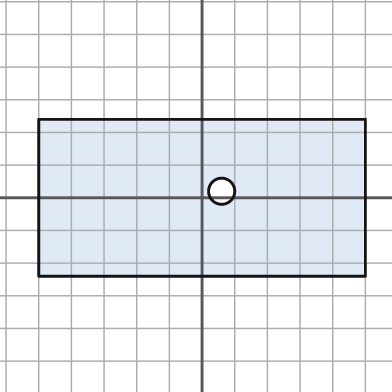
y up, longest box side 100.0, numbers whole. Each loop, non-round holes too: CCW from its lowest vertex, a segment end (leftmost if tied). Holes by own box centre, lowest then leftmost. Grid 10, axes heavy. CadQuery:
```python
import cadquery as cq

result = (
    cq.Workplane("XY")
    .moveTo(-50.0, -24.0)
    .lineTo(50.0, -24.0)
    .lineTo(50.0, 24.0)
    .lineTo(-50.0, 24.0)
    .close()
    .moveTo(6.0, 2.0)
    .circle(4.0)
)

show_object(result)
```